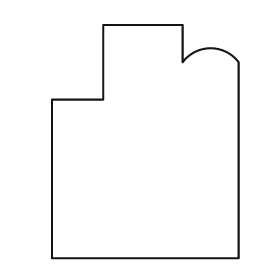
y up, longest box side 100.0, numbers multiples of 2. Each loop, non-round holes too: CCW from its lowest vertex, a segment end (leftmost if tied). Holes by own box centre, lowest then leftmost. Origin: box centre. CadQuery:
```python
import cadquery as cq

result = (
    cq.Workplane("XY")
    .moveTo(-40.0, -50.0)
    .lineTo(40.0, -50.0)
    .lineTo(40.0, 34.0)
    .threePointArc((28.0, 40.0), (16.0, 34.0))
    .lineTo(16.0, 50.0)
    .lineTo(-18.0, 50.0)
    .lineTo(-18.0, 18.0)
    .lineTo(-40.0, 18.0)
    .close()
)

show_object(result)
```